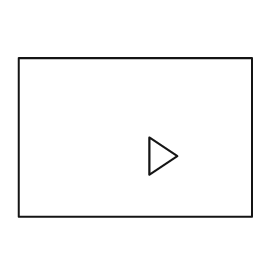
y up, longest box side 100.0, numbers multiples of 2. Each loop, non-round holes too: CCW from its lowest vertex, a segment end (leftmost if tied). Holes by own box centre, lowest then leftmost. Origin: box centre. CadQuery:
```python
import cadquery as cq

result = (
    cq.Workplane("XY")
    .moveTo(-50.0, -34.0)
    .lineTo(50.0, -34.0)
    .lineTo(50.0, 34.0)
    .lineTo(-50.0, 34.0)
    .close()
    .moveTo(6.0, -16.0)
    .lineTo(18.0, -8.0)
    .lineTo(6.0, 0.0)
    .close()
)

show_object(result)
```